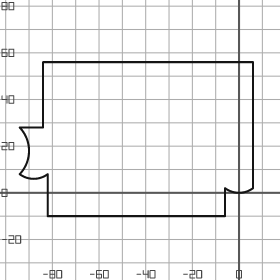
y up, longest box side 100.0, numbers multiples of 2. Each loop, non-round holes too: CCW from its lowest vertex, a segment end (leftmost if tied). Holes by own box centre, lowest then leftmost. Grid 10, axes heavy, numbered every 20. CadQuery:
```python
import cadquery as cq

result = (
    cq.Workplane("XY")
    .moveTo(-82.0, -10.0)
    .lineTo(-6.0, -10.0)
    .lineTo(-6.0, 2.0)
    .threePointArc((0.0, 0.0), (6.0, 2.0))
    .lineTo(6.0, 56.0)
    .lineTo(-84.0, 56.0)
    .lineTo(-84.0, 28.0)
    .lineTo(-94.0, 28.0)
    .threePointArc((-90.0, 18.0), (-94.0, 8.0))
    .threePointArc((-88.0, 6.0), (-82.0, 8.0))
    .close()
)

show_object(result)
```